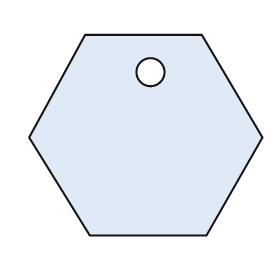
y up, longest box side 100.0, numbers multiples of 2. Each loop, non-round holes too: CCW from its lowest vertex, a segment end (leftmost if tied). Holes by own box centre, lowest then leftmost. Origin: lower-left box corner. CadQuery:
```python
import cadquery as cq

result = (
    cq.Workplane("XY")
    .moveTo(26.0, 0.0)
    .lineTo(76.0, 0.0)
    .lineTo(100.0, 42.0)
    .lineTo(74.0, 86.0)
    .lineTo(24.0, 86.0)
    .lineTo(0.0, 42.0)
    .close()
    .moveTo(52.0, 70.0)
    .circle(6.0)
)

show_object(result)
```